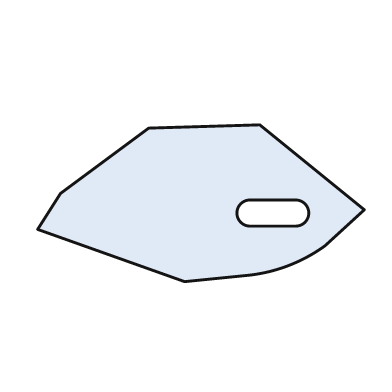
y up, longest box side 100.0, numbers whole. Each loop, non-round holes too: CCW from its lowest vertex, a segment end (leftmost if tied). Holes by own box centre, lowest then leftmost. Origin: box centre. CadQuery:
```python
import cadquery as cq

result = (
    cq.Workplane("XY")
    .moveTo(-5.0, -24.0)
    .lineTo(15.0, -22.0)
    .threePointArc((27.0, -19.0), (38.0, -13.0))
    .lineTo(50.0, -2.0)
    .lineTo(18.0, 24.0)
    .lineTo(-16.0, 23.0)
    .lineTo(-43.0, 3.0)
    .lineTo(-50.0, -8.0)
    .close()
    .moveTo(15.0, -7.0)
    .lineTo(29.0, -7.0)
    .threePointArc((33.0, -3.0), (29.0, 1.0))
    .lineTo(15.0, 1.0)
    .threePointArc((11.0, -3.0), (15.0, -7.0))
    .close()
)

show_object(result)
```